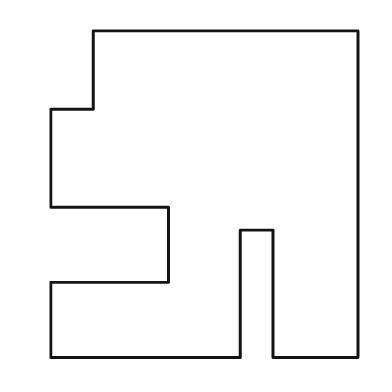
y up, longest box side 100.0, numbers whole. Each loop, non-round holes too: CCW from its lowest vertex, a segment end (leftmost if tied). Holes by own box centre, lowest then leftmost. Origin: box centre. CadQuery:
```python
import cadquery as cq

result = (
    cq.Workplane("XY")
    .moveTo(-47.0, -50.0)
    .lineTo(11.0, -50.0)
    .lineTo(11.0, -11.0)
    .lineTo(21.0, -11.0)
    .lineTo(21.0, -50.0)
    .lineTo(47.0, -50.0)
    .lineTo(47.0, 50.0)
    .lineTo(-34.0, 50.0)
    .lineTo(-34.0, 26.0)
    .lineTo(-47.0, 26.0)
    .lineTo(-47.0, -4.0)
    .lineTo(-11.0, -4.0)
    .lineTo(-11.0, -27.0)
    .lineTo(-47.0, -27.0)
    .close()
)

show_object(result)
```